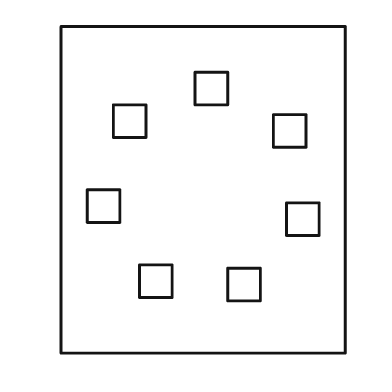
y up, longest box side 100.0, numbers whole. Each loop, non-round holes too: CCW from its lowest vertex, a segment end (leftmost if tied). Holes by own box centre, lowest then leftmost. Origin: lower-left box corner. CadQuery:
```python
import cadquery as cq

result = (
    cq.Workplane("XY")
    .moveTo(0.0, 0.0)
    .lineTo(87.0, 0.0)
    .lineTo(87.0, 100.0)
    .lineTo(0.0, 100.0)
    .close()
    .moveTo(51.0, 16.0)
    .lineTo(61.0, 16.0)
    .lineTo(61.0, 26.0)
    .lineTo(51.0, 26.0)
    .close()
    .moveTo(24.0, 17.0)
    .lineTo(34.0, 17.0)
    .lineTo(34.0, 27.0)
    .lineTo(24.0, 27.0)
    .close()
    .moveTo(69.0, 36.0)
    .lineTo(79.0, 36.0)
    .lineTo(79.0, 46.0)
    .lineTo(69.0, 46.0)
    .close()
    .moveTo(8.0, 40.0)
    .lineTo(18.0, 40.0)
    .lineTo(18.0, 50.0)
    .lineTo(8.0, 50.0)
    .close()
    .moveTo(65.0, 63.0)
    .lineTo(75.0, 63.0)
    .lineTo(75.0, 73.0)
    .lineTo(65.0, 73.0)
    .close()
    .moveTo(16.0, 66.0)
    .lineTo(26.0, 66.0)
    .lineTo(26.0, 76.0)
    .lineTo(16.0, 76.0)
    .close()
    .moveTo(41.0, 76.0)
    .lineTo(51.0, 76.0)
    .lineTo(51.0, 86.0)
    .lineTo(41.0, 86.0)
    .close()
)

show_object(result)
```